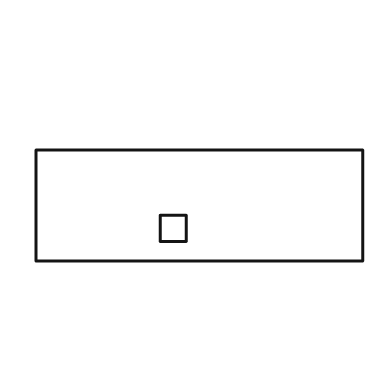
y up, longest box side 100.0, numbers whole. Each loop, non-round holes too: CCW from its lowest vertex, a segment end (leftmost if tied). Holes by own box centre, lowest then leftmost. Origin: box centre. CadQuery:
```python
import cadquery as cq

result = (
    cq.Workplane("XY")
    .moveTo(-50.0, -17.0)
    .lineTo(50.0, -17.0)
    .lineTo(50.0, 17.0)
    .lineTo(-50.0, 17.0)
    .close()
    .moveTo(-12.0, -11.0)
    .lineTo(-4.0, -11.0)
    .lineTo(-4.0, -3.0)
    .lineTo(-12.0, -3.0)
    .close()
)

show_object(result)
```